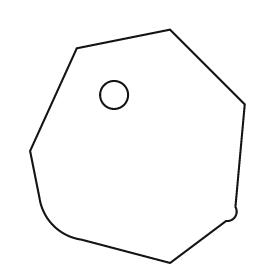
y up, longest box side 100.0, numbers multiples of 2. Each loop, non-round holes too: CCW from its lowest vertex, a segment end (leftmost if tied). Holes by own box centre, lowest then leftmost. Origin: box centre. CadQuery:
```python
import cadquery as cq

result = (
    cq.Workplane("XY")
    .moveTo(14.0, -50.0)
    .lineTo(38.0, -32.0)
    .threePointArc((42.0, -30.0), (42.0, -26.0))
    .lineTo(46.0, 18.0)
    .lineTo(14.0, 50.0)
    .lineTo(-26.0, 42.0)
    .lineTo(-46.0, -2.0)
    .lineTo(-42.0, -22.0)
    .threePointArc((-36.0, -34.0), (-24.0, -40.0))
    .close()
    .moveTo(-10.0, 22.0)
    .circle(6.0)
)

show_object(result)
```